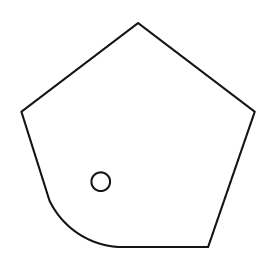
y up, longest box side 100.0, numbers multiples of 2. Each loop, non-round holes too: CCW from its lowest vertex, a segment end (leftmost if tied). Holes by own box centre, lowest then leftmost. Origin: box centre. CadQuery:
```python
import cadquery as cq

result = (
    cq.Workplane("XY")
    .moveTo(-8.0, -48.0)
    .lineTo(30.0, -48.0)
    .lineTo(50.0, 10.0)
    .lineTo(0.0, 48.0)
    .lineTo(-50.0, 10.0)
    .lineTo(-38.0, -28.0)
    .threePointArc((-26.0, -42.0), (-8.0, -48.0))
    .close()
    .moveTo(-16.0, -20.0)
    .circle(4.0)
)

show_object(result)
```